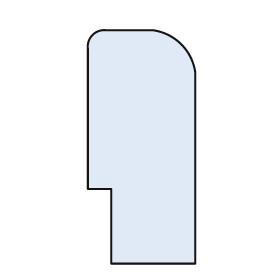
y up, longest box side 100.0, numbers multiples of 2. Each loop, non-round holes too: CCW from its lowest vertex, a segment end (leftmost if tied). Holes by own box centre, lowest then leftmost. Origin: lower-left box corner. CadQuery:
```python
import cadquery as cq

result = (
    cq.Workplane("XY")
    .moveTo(10.0, 0.0)
    .lineTo(46.0, 0.0)
    .lineTo(46.0, 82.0)
    .threePointArc((40.0, 94.0), (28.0, 100.0))
    .lineTo(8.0, 100.0)
    .threePointArc((2.0, 98.0), (0.0, 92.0))
    .lineTo(0.0, 32.0)
    .lineTo(10.0, 32.0)
    .close()
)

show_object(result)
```